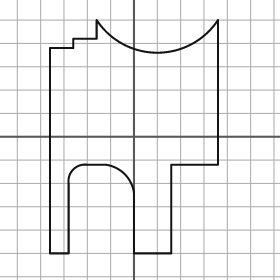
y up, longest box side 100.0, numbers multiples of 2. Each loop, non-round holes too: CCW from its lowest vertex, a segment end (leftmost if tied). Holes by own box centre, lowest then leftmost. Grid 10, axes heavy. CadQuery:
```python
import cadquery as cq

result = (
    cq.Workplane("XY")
    .moveTo(-36.0, -50.0)
    .lineTo(-28.0, -50.0)
    .lineTo(-28.0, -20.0)
    .threePointArc((-26.0, -14.0), (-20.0, -12.0))
    .lineTo(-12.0, -12.0)
    .threePointArc((-4.0, -16.0), (0.0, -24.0))
    .lineTo(0.0, -50.0)
    .lineTo(16.0, -50.0)
    .lineTo(16.0, -12.0)
    .lineTo(36.0, -12.0)
    .lineTo(36.0, 50.0)
    .threePointArc((10.0, 36.0), (-16.0, 50.0))
    .lineTo(-16.0, 42.0)
    .lineTo(-26.0, 42.0)
    .lineTo(-26.0, 38.0)
    .lineTo(-36.0, 38.0)
    .close()
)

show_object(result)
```